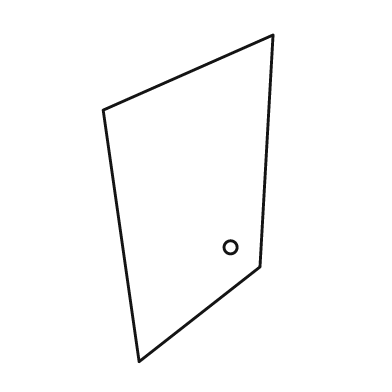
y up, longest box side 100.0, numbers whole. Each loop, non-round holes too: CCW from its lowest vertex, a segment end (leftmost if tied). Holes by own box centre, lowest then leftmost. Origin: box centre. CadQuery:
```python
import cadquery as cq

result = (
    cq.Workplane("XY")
    .moveTo(-15.0, -50.0)
    .lineTo(22.0, -21.0)
    .lineTo(26.0, 50.0)
    .lineTo(-26.0, 27.0)
    .close()
    .moveTo(13.0, -15.0)
    .circle(2.0)
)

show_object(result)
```